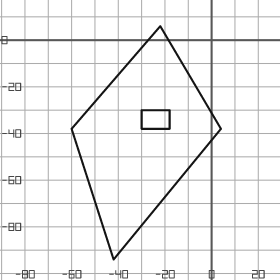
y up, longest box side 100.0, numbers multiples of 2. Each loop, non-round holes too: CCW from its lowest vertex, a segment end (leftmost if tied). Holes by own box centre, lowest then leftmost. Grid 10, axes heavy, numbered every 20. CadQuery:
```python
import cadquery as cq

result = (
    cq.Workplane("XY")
    .moveTo(-42.0, -94.0)
    .lineTo(4.0, -38.0)
    .lineTo(-22.0, 6.0)
    .lineTo(-60.0, -38.0)
    .close()
    .moveTo(-30.0, -38.0)
    .lineTo(-18.0, -38.0)
    .lineTo(-18.0, -30.0)
    .lineTo(-30.0, -30.0)
    .close()
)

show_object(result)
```